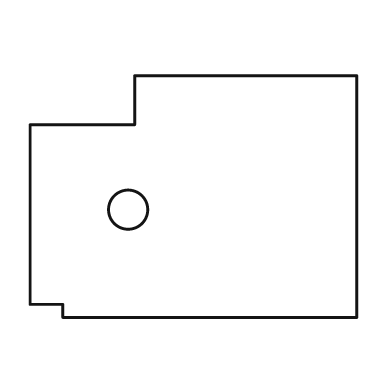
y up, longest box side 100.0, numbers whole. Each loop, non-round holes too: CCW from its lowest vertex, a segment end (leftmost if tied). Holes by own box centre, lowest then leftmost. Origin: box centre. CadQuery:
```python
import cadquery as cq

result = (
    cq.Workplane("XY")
    .moveTo(-40.0, -37.0)
    .lineTo(50.0, -37.0)
    .lineTo(50.0, 37.0)
    .lineTo(-18.0, 37.0)
    .lineTo(-18.0, 22.0)
    .lineTo(-50.0, 22.0)
    .lineTo(-50.0, -33.0)
    .lineTo(-40.0, -33.0)
    .close()
    .moveTo(-20.0, -4.0)
    .circle(6.0)
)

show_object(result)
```